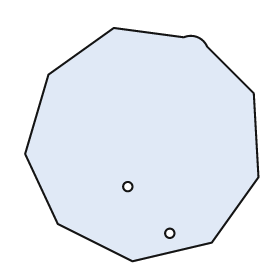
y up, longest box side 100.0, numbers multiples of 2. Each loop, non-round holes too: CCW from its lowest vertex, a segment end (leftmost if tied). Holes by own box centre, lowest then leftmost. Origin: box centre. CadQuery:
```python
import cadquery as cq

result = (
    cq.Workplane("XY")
    .moveTo(-4.0, -50.0)
    .lineTo(30.0, -42.0)
    .lineTo(50.0, -14.0)
    .lineTo(48.0, 22.0)
    .lineTo(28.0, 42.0)
    .threePointArc((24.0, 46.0), (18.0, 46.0))
    .lineTo(-12.0, 50.0)
    .lineTo(-40.0, 30.0)
    .lineTo(-50.0, -4.0)
    .lineTo(-36.0, -34.0)
    .close()
    .moveTo(12.0, -38.0)
    .circle(2.0)
    .moveTo(-6.0, -18.0)
    .circle(2.0)
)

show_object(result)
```